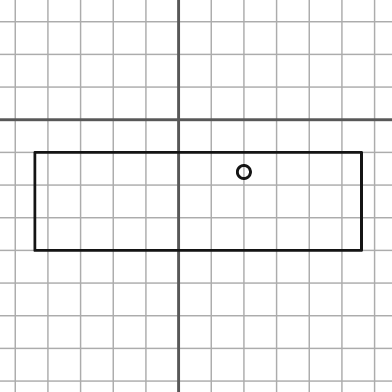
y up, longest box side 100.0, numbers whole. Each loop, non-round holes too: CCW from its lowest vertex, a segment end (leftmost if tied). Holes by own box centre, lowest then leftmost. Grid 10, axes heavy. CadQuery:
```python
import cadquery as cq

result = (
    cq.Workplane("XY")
    .moveTo(-44.0, -40.0)
    .lineTo(56.0, -40.0)
    .lineTo(56.0, -10.0)
    .lineTo(-44.0, -10.0)
    .close()
    .moveTo(20.0, -16.0)
    .circle(2.0)
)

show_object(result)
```